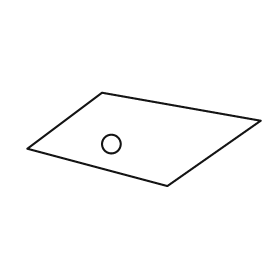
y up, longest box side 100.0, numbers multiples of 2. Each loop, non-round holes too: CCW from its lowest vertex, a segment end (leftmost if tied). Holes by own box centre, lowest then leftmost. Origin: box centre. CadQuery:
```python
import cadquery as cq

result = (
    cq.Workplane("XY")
    .moveTo(10.0, -20.0)
    .lineTo(50.0, 8.0)
    .lineTo(-18.0, 20.0)
    .lineTo(-50.0, -4.0)
    .close()
    .moveTo(-14.0, -2.0)
    .circle(4.0)
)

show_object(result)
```